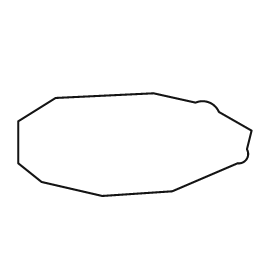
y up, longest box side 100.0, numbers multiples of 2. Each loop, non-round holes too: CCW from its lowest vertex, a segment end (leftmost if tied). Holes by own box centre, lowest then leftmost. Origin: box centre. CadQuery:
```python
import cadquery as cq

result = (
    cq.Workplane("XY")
    .moveTo(-14.0, -22.0)
    .lineTo(16.0, -20.0)
    .lineTo(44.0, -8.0)
    .threePointArc((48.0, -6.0), (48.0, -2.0))
    .lineTo(50.0, 6.0)
    .lineTo(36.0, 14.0)
    .threePointArc((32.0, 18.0), (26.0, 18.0))
    .lineTo(8.0, 22.0)
    .lineTo(-34.0, 20.0)
    .lineTo(-50.0, 10.0)
    .lineTo(-50.0, -8.0)
    .lineTo(-40.0, -16.0)
    .close()
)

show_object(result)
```